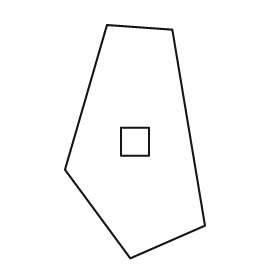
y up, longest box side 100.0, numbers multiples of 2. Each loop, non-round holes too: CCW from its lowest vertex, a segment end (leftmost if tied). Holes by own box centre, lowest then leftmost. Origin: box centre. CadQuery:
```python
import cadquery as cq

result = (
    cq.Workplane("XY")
    .moveTo(-2.0, -50.0)
    .lineTo(30.0, -36.0)
    .lineTo(16.0, 48.0)
    .lineTo(-12.0, 50.0)
    .lineTo(-30.0, -12.0)
    .close()
    .moveTo(-6.0, -6.0)
    .lineTo(6.0, -6.0)
    .lineTo(6.0, 6.0)
    .lineTo(-6.0, 6.0)
    .close()
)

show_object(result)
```